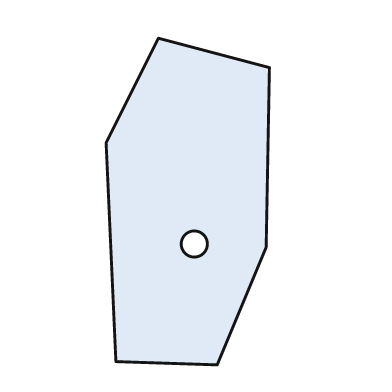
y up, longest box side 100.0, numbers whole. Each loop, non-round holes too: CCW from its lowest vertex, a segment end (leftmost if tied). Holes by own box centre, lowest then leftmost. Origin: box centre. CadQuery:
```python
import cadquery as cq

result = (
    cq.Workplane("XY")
    .moveTo(9.0, -50.0)
    .lineTo(24.0, -14.0)
    .lineTo(25.0, 41.0)
    .lineTo(-9.0, 50.0)
    .lineTo(-25.0, 18.0)
    .lineTo(-22.0, -49.0)
    .close()
    .moveTo(2.0, -13.0)
    .circle(4.0)
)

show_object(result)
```